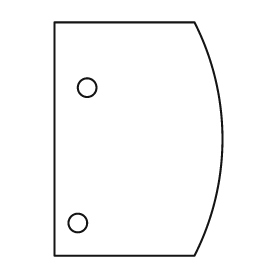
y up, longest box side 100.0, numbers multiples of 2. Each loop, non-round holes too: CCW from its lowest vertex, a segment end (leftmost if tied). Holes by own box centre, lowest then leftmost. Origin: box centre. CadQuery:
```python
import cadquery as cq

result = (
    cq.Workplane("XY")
    .moveTo(-36.0, -50.0)
    .lineTo(24.0, -50.0)
    .threePointArc((36.0, 0.0), (24.0, 50.0))
    .lineTo(-36.0, 50.0)
    .close()
    .moveTo(-26.0, -36.0)
    .circle(4.0)
    .moveTo(-22.0, 22.0)
    .circle(4.0)
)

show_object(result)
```